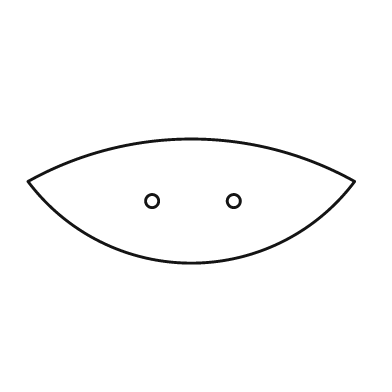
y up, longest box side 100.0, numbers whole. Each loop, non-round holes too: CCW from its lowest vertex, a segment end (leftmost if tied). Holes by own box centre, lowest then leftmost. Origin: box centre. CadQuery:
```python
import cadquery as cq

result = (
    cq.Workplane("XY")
    .moveTo(-50.0, 6.0)
    .threePointArc((0.0, -19.0), (50.0, 6.0))
    .threePointArc((0.0, 19.0), (-50.0, 6.0))
    .close()
    .moveTo(-12.0, 0.0)
    .circle(2.0)
    .moveTo(13.0, 0.0)
    .circle(2.0)
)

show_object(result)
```